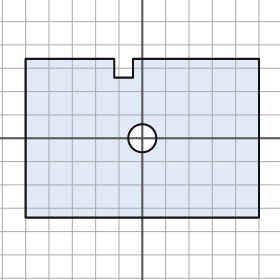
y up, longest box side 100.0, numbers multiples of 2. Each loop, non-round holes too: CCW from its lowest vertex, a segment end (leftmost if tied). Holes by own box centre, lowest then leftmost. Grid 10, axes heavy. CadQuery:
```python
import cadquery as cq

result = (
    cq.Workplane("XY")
    .moveTo(-50.0, -34.0)
    .lineTo(50.0, -34.0)
    .lineTo(50.0, 34.0)
    .lineTo(-4.0, 34.0)
    .lineTo(-4.0, 26.0)
    .lineTo(-12.0, 26.0)
    .lineTo(-12.0, 34.0)
    .lineTo(-50.0, 34.0)
    .close()
    .moveTo(0.0, 0.0)
    .circle(6.0)
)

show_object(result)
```